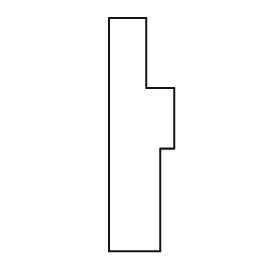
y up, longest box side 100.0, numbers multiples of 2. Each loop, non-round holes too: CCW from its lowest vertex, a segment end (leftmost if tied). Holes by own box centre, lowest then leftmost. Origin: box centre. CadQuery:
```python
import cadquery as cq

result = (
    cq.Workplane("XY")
    .moveTo(-14.0, -50.0)
    .lineTo(8.0, -50.0)
    .lineTo(8.0, -6.0)
    .lineTo(14.0, -6.0)
    .lineTo(14.0, 20.0)
    .lineTo(2.0, 20.0)
    .lineTo(2.0, 50.0)
    .lineTo(-14.0, 50.0)
    .close()
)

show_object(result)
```